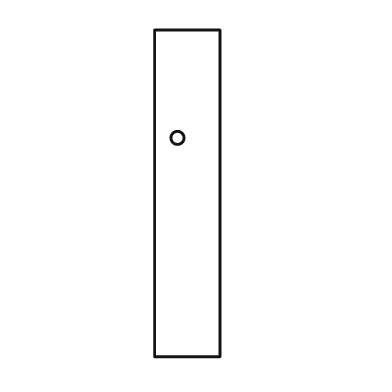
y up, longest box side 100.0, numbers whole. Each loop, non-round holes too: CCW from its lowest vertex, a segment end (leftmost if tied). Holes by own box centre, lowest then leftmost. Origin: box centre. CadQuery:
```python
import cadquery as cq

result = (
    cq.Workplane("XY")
    .moveTo(-10.0, -50.0)
    .lineTo(10.0, -50.0)
    .lineTo(10.0, 50.0)
    .lineTo(-10.0, 50.0)
    .close()
    .moveTo(-3.0, 17.0)
    .circle(2.0)
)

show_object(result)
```